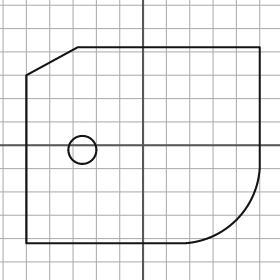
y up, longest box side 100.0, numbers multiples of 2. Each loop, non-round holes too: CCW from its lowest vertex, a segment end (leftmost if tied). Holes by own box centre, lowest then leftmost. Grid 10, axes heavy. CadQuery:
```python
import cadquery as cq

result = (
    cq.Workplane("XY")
    .moveTo(-50.0, -42.0)
    .lineTo(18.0, -42.0)
    .threePointArc((40.0, -32.0), (50.0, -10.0))
    .lineTo(50.0, 42.0)
    .lineTo(-28.0, 42.0)
    .lineTo(-50.0, 30.0)
    .close()
    .moveTo(-26.0, -2.0)
    .circle(6.0)
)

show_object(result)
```